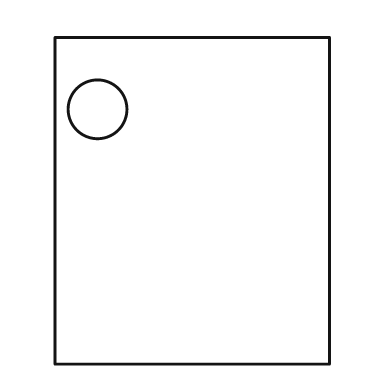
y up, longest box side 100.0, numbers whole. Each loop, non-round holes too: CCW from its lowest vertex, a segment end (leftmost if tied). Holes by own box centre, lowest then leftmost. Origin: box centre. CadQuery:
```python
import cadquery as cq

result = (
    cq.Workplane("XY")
    .moveTo(-42.0, -50.0)
    .lineTo(42.0, -50.0)
    .lineTo(42.0, 50.0)
    .lineTo(-42.0, 50.0)
    .close()
    .moveTo(-29.0, 28.0)
    .circle(9.0)
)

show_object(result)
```